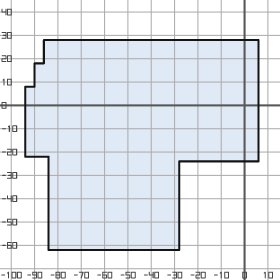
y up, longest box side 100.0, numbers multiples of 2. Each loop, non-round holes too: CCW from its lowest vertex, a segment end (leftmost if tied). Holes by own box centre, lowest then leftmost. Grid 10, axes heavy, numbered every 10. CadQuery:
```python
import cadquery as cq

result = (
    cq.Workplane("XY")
    .moveTo(-84.0, -62.0)
    .lineTo(-28.0, -62.0)
    .lineTo(-28.0, -24.0)
    .lineTo(6.0, -24.0)
    .lineTo(6.0, 28.0)
    .lineTo(-86.0, 28.0)
    .lineTo(-86.0, 18.0)
    .lineTo(-90.0, 18.0)
    .lineTo(-90.0, 8.0)
    .lineTo(-94.0, 8.0)
    .lineTo(-94.0, -22.0)
    .lineTo(-84.0, -22.0)
    .close()
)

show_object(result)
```